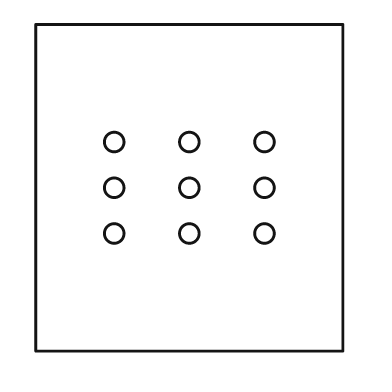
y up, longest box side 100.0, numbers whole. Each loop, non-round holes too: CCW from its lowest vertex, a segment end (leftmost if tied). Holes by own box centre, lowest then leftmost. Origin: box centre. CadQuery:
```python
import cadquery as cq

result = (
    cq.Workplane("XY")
    .moveTo(-47.0, -50.0)
    .lineTo(47.0, -50.0)
    .lineTo(47.0, 50.0)
    .lineTo(-47.0, 50.0)
    .close()
    .moveTo(-23.0, -14.0)
    .circle(3.0)
    .moveTo(0.0, -14.0)
    .circle(3.0)
    .moveTo(23.0, -14.0)
    .circle(3.0)
    .moveTo(-23.0, 0.0)
    .circle(3.0)
    .moveTo(0.0, 0.0)
    .circle(3.0)
    .moveTo(23.0, 0.0)
    .circle(3.0)
    .moveTo(-23.0, 14.0)
    .circle(3.0)
    .moveTo(0.0, 14.0)
    .circle(3.0)
    .moveTo(23.0, 14.0)
    .circle(3.0)
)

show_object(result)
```